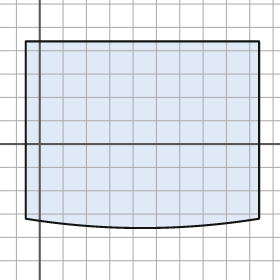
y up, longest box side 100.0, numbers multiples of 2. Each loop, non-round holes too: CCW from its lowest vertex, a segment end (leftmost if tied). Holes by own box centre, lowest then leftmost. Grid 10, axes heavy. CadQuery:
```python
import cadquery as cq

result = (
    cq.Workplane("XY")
    .moveTo(-6.0, -32.0)
    .threePointArc((44.0, -36.0), (94.0, -32.0))
    .lineTo(94.0, 44.0)
    .lineTo(-6.0, 44.0)
    .close()
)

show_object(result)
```